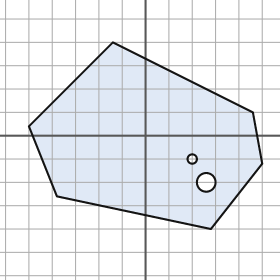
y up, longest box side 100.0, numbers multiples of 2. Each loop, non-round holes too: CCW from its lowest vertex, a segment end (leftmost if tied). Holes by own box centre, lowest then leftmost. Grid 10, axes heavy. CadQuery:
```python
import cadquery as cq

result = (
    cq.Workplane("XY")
    .moveTo(28.0, -40.0)
    .lineTo(50.0, -12.0)
    .lineTo(46.0, 10.0)
    .lineTo(-14.0, 40.0)
    .lineTo(-50.0, 4.0)
    .lineTo(-38.0, -26.0)
    .close()
    .moveTo(26.0, -20.0)
    .circle(4.0)
    .moveTo(20.0, -10.0)
    .circle(2.0)
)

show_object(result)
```